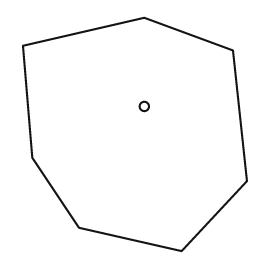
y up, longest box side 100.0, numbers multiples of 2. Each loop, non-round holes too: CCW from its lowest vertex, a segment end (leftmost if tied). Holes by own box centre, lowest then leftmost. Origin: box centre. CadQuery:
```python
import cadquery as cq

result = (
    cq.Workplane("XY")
    .moveTo(20.0, -50.0)
    .lineTo(48.0, -20.0)
    .lineTo(42.0, 36.0)
    .lineTo(4.0, 50.0)
    .lineTo(-48.0, 38.0)
    .lineTo(-44.0, -10.0)
    .lineTo(-24.0, -40.0)
    .close()
    .moveTo(4.0, 12.0)
    .circle(2.0)
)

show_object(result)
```